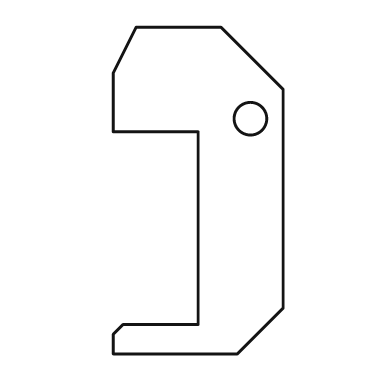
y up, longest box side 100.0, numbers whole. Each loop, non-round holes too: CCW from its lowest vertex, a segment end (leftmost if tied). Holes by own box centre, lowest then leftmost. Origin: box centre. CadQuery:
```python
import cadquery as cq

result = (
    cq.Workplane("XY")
    .moveTo(-26.0, -50.0)
    .lineTo(12.0, -50.0)
    .lineTo(26.0, -36.0)
    .lineTo(26.0, 31.0)
    .lineTo(7.0, 50.0)
    .lineTo(-19.0, 50.0)
    .lineTo(-26.0, 36.0)
    .lineTo(-26.0, 18.0)
    .lineTo(0.0, 18.0)
    .lineTo(0.0, -41.0)
    .lineTo(-23.0, -41.0)
    .lineTo(-26.0, -44.0)
    .close()
    .moveTo(16.0, 22.0)
    .circle(5.0)
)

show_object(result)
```